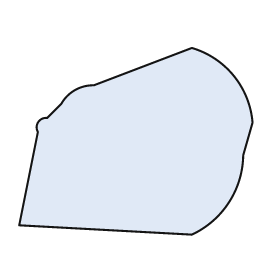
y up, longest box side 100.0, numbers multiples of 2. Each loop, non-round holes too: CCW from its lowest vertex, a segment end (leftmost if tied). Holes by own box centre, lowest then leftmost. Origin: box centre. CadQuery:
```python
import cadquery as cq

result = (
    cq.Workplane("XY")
    .moveTo(24.0, -40.0)
    .threePointArc((40.0, -26.0), (46.0, -6.0))
    .lineTo(50.0, 8.0)
    .threePointArc((42.0, 28.0), (24.0, 40.0))
    .lineTo(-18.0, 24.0)
    .threePointArc((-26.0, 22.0), (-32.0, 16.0))
    .lineTo(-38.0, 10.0)
    .threePointArc((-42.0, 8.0), (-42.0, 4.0))
    .lineTo(-50.0, -36.0)
    .close()
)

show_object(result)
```